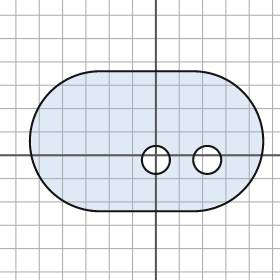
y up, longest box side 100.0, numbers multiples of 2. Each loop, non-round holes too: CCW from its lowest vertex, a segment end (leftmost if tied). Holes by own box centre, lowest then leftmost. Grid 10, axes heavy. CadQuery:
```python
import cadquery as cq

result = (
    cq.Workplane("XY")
    .moveTo(-24.0, -24.0)
    .lineTo(16.0, -24.0)
    .threePointArc((46.0, 6.0), (16.0, 36.0))
    .lineTo(-24.0, 36.0)
    .threePointArc((-54.0, 6.0), (-24.0, -24.0))
    .close()
    .moveTo(0.0, -2.0)
    .circle(6.0)
    .moveTo(22.0, -2.0)
    .circle(6.0)
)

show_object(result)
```